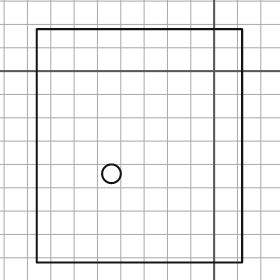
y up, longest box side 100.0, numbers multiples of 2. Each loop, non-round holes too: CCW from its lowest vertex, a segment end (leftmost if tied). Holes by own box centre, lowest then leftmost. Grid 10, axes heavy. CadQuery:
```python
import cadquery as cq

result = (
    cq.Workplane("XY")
    .moveTo(-76.0, -82.0)
    .lineTo(12.0, -82.0)
    .lineTo(12.0, 18.0)
    .lineTo(-76.0, 18.0)
    .close()
    .moveTo(-44.0, -44.0)
    .circle(4.0)
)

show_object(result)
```